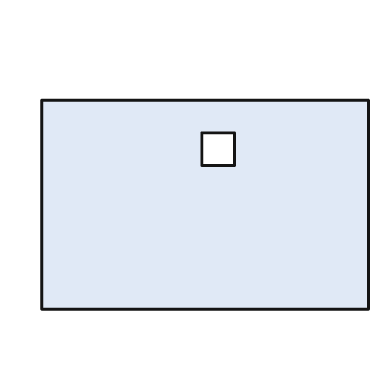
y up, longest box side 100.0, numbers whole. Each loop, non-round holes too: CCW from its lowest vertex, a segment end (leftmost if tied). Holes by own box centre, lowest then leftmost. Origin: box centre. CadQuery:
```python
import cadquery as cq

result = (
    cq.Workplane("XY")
    .moveTo(-50.0, -32.0)
    .lineTo(50.0, -32.0)
    .lineTo(50.0, 32.0)
    .lineTo(-50.0, 32.0)
    .close()
    .moveTo(-1.0, 12.0)
    .lineTo(9.0, 12.0)
    .lineTo(9.0, 22.0)
    .lineTo(-1.0, 22.0)
    .close()
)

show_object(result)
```